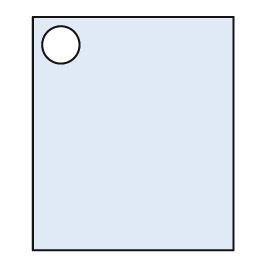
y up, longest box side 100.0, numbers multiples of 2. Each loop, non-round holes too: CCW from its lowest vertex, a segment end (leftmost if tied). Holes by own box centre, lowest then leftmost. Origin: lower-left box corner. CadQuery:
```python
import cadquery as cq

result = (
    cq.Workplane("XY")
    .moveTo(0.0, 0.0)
    .lineTo(86.0, 0.0)
    .lineTo(86.0, 100.0)
    .lineTo(0.0, 100.0)
    .close()
    .moveTo(12.0, 88.0)
    .circle(8.0)
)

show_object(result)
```